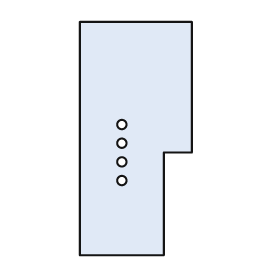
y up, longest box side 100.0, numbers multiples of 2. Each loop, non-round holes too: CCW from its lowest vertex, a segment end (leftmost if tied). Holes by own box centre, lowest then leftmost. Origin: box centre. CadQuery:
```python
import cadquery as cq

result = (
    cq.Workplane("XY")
    .moveTo(-24.0, -50.0)
    .lineTo(12.0, -50.0)
    .lineTo(12.0, -6.0)
    .lineTo(24.0, -6.0)
    .lineTo(24.0, 50.0)
    .lineTo(-24.0, 50.0)
    .close()
    .moveTo(-6.0, -18.0)
    .circle(2.0)
    .moveTo(-6.0, -10.0)
    .circle(2.0)
    .moveTo(-6.0, -2.0)
    .circle(2.0)
    .moveTo(-6.0, 6.0)
    .circle(2.0)
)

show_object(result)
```